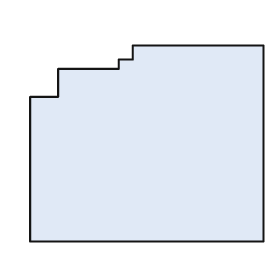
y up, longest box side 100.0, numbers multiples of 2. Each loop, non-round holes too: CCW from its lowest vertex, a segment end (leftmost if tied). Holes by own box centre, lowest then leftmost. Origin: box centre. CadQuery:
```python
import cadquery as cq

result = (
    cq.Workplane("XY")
    .moveTo(-50.0, -42.0)
    .lineTo(50.0, -42.0)
    .lineTo(50.0, 42.0)
    .lineTo(-6.0, 42.0)
    .lineTo(-6.0, 36.0)
    .lineTo(-12.0, 36.0)
    .lineTo(-12.0, 32.0)
    .lineTo(-38.0, 32.0)
    .lineTo(-38.0, 20.0)
    .lineTo(-50.0, 20.0)
    .close()
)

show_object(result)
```